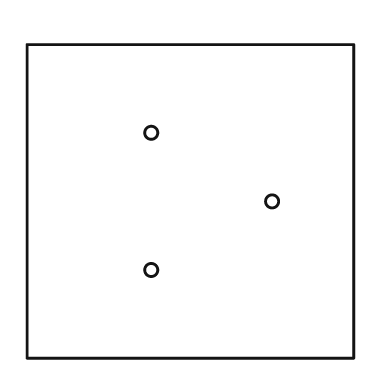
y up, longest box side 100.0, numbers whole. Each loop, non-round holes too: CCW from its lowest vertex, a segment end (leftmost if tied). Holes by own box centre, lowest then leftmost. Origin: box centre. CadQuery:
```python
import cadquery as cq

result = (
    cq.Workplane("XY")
    .moveTo(-50.0, -48.0)
    .lineTo(50.0, -48.0)
    .lineTo(50.0, 48.0)
    .lineTo(-50.0, 48.0)
    .close()
    .moveTo(-12.0, -21.0)
    .circle(2.0)
    .moveTo(25.0, 0.0)
    .circle(2.0)
    .moveTo(-12.0, 21.0)
    .circle(2.0)
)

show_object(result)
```